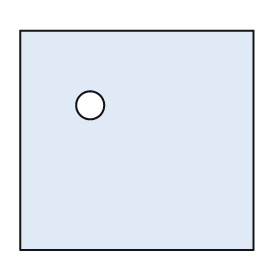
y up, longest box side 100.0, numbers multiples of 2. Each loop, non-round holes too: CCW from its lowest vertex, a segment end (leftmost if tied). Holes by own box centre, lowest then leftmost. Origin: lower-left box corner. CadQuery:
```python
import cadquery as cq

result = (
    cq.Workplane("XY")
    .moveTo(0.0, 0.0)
    .lineTo(100.0, 0.0)
    .lineTo(100.0, 94.0)
    .lineTo(0.0, 94.0)
    .close()
    .moveTo(30.0, 62.0)
    .circle(6.0)
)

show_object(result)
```